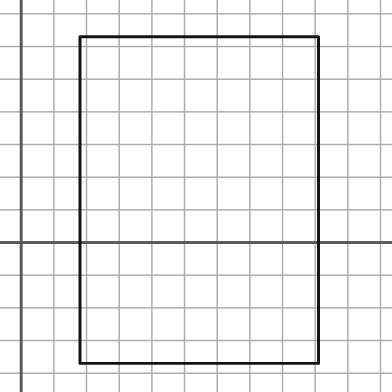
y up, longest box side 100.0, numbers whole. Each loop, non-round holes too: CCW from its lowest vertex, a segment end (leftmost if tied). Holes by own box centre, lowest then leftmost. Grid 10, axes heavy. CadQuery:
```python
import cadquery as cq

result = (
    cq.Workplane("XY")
    .moveTo(18.0, -37.0)
    .lineTo(91.0, -37.0)
    .lineTo(91.0, 63.0)
    .lineTo(18.0, 63.0)
    .close()
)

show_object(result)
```